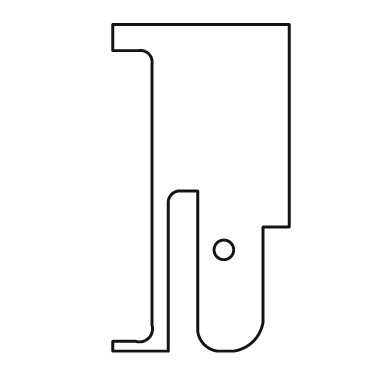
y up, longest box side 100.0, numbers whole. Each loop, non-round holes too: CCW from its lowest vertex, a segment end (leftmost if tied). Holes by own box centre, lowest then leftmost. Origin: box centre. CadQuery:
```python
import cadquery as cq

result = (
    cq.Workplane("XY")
    .moveTo(-27.0, -50.0)
    .lineTo(-10.0, -50.0)
    .lineTo(-10.0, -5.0)
    .threePointArc((-9.0, -2.0), (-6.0, -1.0))
    .lineTo(-1.0, -1.0)
    .lineTo(-1.0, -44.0)
    .threePointArc((1.0, -48.0), (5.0, -50.0))
    .lineTo(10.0, -50.0)
    .threePointArc((16.0, -47.0), (19.0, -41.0))
    .lineTo(19.0, -12.0)
    .lineTo(27.0, -12.0)
    .lineTo(27.0, 50.0)
    .lineTo(-27.0, 50.0)
    .lineTo(-27.0, 42.0)
    .lineTo(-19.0, 42.0)
    .threePointArc((-16.0, 41.0), (-15.0, 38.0))
    .lineTo(-15.0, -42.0)
    .threePointArc((-16.0, -46.0), (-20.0, -47.0))
    .lineTo(-27.0, -47.0)
    .close()
    .moveTo(7.0, -19.0)
    .circle(3.0)
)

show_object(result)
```